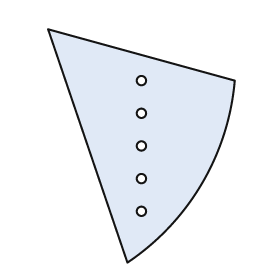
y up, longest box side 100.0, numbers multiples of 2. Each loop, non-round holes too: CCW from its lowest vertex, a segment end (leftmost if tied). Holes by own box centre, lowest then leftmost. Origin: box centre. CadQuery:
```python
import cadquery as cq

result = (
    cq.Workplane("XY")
    .moveTo(-6.0, -50.0)
    .threePointArc((26.0, -16.0), (40.0, 28.0))
    .lineTo(-40.0, 50.0)
    .close()
    .moveTo(0.0, -28.0)
    .circle(2.0)
    .moveTo(0.0, -14.0)
    .circle(2.0)
    .moveTo(0.0, 0.0)
    .circle(2.0)
    .moveTo(0.0, 14.0)
    .circle(2.0)
    .moveTo(0.0, 28.0)
    .circle(2.0)
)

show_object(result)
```